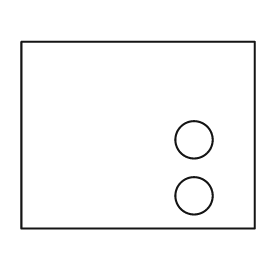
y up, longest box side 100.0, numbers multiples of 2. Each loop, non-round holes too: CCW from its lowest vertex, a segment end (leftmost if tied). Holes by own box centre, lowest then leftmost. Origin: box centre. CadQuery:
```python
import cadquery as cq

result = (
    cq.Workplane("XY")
    .moveTo(-50.0, -40.0)
    .lineTo(50.0, -40.0)
    .lineTo(50.0, 40.0)
    .lineTo(-50.0, 40.0)
    .close()
    .moveTo(24.0, -26.0)
    .circle(8.0)
    .moveTo(24.0, -2.0)
    .circle(8.0)
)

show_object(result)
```